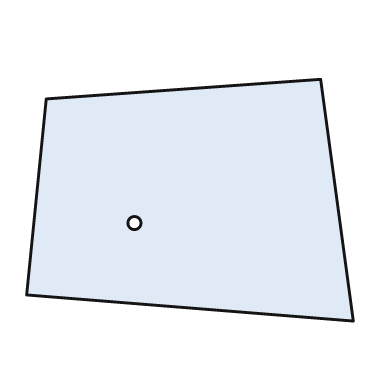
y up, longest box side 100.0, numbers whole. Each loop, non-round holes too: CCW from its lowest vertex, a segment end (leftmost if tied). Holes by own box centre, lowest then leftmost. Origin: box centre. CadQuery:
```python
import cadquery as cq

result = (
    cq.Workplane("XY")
    .moveTo(50.0, -37.0)
    .lineTo(40.0, 37.0)
    .lineTo(-44.0, 31.0)
    .lineTo(-50.0, -29.0)
    .close()
    .moveTo(-17.0, -7.0)
    .circle(2.0)
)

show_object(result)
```